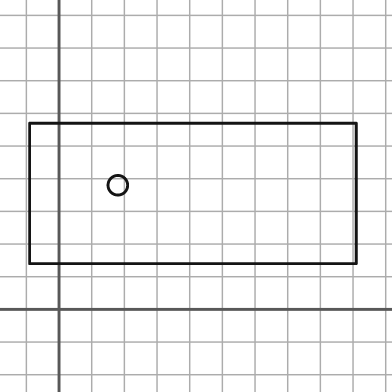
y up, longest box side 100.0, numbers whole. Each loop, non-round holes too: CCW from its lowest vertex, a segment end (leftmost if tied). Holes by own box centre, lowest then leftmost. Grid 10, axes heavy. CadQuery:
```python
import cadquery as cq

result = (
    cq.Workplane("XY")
    .moveTo(-9.0, 14.0)
    .lineTo(91.0, 14.0)
    .lineTo(91.0, 57.0)
    .lineTo(-9.0, 57.0)
    .close()
    .moveTo(18.0, 38.0)
    .circle(3.0)
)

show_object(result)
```